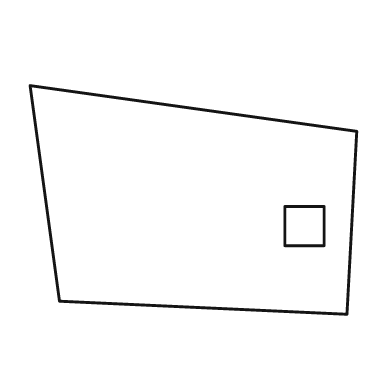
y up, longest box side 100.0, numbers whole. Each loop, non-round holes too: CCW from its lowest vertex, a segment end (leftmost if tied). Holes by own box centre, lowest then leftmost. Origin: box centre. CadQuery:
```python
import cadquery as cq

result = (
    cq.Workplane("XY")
    .moveTo(47.0, -35.0)
    .lineTo(50.0, 21.0)
    .lineTo(-50.0, 35.0)
    .lineTo(-41.0, -31.0)
    .close()
    .moveTo(28.0, -14.0)
    .lineTo(40.0, -14.0)
    .lineTo(40.0, -2.0)
    .lineTo(28.0, -2.0)
    .close()
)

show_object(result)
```